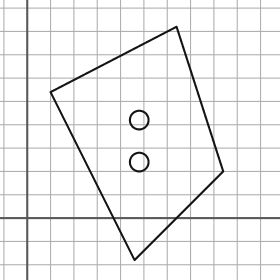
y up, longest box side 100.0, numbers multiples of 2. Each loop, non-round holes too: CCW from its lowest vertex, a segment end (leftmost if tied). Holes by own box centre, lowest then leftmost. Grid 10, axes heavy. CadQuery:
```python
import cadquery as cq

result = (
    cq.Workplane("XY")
    .moveTo(46.0, -18.0)
    .lineTo(84.0, 20.0)
    .lineTo(64.0, 82.0)
    .lineTo(10.0, 54.0)
    .close()
    .moveTo(48.0, 24.0)
    .circle(4.0)
    .moveTo(48.0, 42.0)
    .circle(4.0)
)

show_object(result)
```